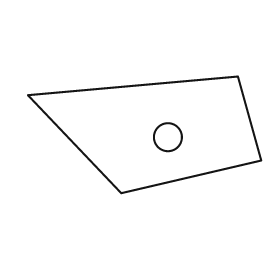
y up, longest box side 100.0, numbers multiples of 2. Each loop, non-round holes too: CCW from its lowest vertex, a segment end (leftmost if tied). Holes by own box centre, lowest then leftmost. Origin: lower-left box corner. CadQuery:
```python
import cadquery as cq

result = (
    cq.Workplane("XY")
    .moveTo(40.0, 0.0)
    .lineTo(100.0, 14.0)
    .lineTo(90.0, 50.0)
    .lineTo(0.0, 42.0)
    .close()
    .moveTo(60.0, 24.0)
    .circle(6.0)
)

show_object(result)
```